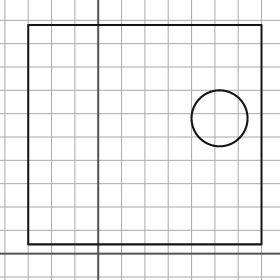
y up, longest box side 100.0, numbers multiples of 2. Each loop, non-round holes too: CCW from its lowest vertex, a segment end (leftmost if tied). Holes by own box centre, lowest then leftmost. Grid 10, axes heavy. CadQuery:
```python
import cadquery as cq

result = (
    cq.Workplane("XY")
    .moveTo(-30.0, 4.0)
    .lineTo(70.0, 4.0)
    .lineTo(70.0, 98.0)
    .lineTo(-30.0, 98.0)
    .close()
    .moveTo(52.0, 58.0)
    .circle(12.0)
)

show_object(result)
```